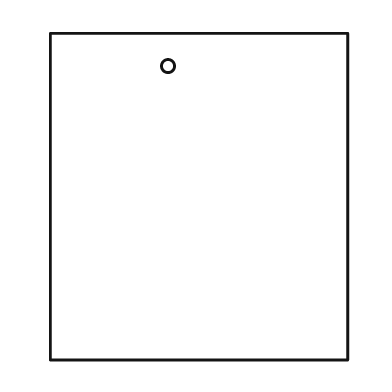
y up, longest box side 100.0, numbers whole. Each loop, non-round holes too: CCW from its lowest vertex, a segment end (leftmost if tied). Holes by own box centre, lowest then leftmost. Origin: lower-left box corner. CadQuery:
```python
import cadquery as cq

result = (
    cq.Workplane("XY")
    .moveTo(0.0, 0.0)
    .lineTo(91.0, 0.0)
    .lineTo(91.0, 100.0)
    .lineTo(0.0, 100.0)
    .close()
    .moveTo(36.0, 90.0)
    .circle(2.0)
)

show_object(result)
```